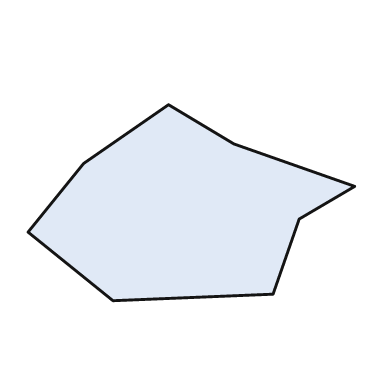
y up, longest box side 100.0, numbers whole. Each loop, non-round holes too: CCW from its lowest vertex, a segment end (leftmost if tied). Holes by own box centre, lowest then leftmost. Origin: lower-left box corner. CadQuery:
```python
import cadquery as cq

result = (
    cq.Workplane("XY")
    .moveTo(26.0, 0.0)
    .lineTo(75.0, 2.0)
    .lineTo(83.0, 25.0)
    .lineTo(100.0, 35.0)
    .lineTo(63.0, 48.0)
    .lineTo(43.0, 60.0)
    .lineTo(17.0, 42.0)
    .lineTo(0.0, 21.0)
    .close()
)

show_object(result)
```